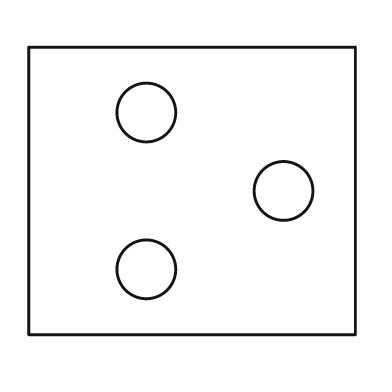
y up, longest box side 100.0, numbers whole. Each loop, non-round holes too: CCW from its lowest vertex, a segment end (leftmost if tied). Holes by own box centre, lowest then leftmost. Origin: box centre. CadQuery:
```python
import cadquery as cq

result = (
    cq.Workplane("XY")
    .moveTo(-50.0, -44.0)
    .lineTo(50.0, -44.0)
    .lineTo(50.0, 44.0)
    .lineTo(-50.0, 44.0)
    .close()
    .moveTo(-14.0, -24.0)
    .circle(9.0)
    .moveTo(28.0, 0.0)
    .circle(9.0)
    .moveTo(-14.0, 24.0)
    .circle(9.0)
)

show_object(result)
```